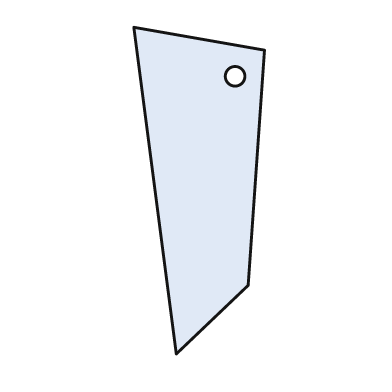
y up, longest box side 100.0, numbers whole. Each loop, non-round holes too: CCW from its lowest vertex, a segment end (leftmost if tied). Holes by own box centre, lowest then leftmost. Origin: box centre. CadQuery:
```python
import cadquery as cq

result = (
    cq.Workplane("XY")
    .moveTo(-7.0, -50.0)
    .lineTo(15.0, -29.0)
    .lineTo(20.0, 43.0)
    .lineTo(-20.0, 50.0)
    .close()
    .moveTo(11.0, 35.0)
    .circle(3.0)
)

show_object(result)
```